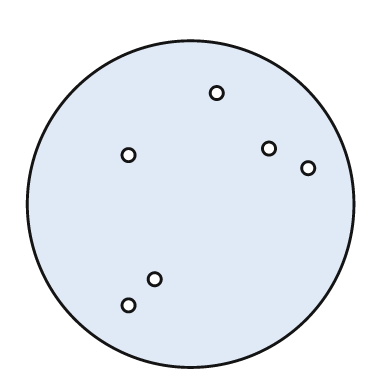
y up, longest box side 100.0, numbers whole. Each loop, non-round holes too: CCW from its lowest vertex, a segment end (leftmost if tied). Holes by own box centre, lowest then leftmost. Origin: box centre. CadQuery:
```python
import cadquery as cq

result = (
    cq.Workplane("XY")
    .moveTo(0.0, 0.0)
    .circle(50.0)
    .moveTo(-19.0, -31.0)
    .circle(2.0)
    .moveTo(-11.0, -23.0)
    .circle(2.0)
    .moveTo(36.0, 11.0)
    .circle(2.0)
    .moveTo(-19.0, 15.0)
    .circle(2.0)
    .moveTo(24.0, 17.0)
    .circle(2.0)
    .moveTo(8.0, 34.0)
    .circle(2.0)
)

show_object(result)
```